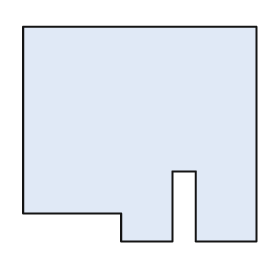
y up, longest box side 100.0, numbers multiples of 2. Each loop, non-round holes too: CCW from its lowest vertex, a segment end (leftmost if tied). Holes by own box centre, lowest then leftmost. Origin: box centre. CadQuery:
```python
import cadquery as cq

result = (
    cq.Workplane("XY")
    .moveTo(-8.0, -46.0)
    .lineTo(14.0, -46.0)
    .lineTo(14.0, -16.0)
    .lineTo(24.0, -16.0)
    .lineTo(24.0, -46.0)
    .lineTo(50.0, -46.0)
    .lineTo(50.0, 46.0)
    .lineTo(-50.0, 46.0)
    .lineTo(-50.0, -34.0)
    .lineTo(-8.0, -34.0)
    .close()
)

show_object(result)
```